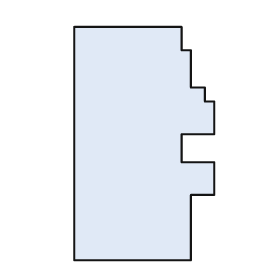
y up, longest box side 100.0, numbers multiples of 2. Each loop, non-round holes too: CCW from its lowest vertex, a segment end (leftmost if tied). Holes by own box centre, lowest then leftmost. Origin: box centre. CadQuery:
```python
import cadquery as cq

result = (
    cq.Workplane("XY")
    .moveTo(-30.0, -50.0)
    .lineTo(20.0, -50.0)
    .lineTo(20.0, -22.0)
    .lineTo(30.0, -22.0)
    .lineTo(30.0, -8.0)
    .lineTo(16.0, -8.0)
    .lineTo(16.0, 4.0)
    .lineTo(30.0, 4.0)
    .lineTo(30.0, 18.0)
    .lineTo(26.0, 18.0)
    .lineTo(26.0, 24.0)
    .lineTo(20.0, 24.0)
    .lineTo(20.0, 40.0)
    .lineTo(16.0, 40.0)
    .lineTo(16.0, 50.0)
    .lineTo(-30.0, 50.0)
    .close()
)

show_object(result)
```